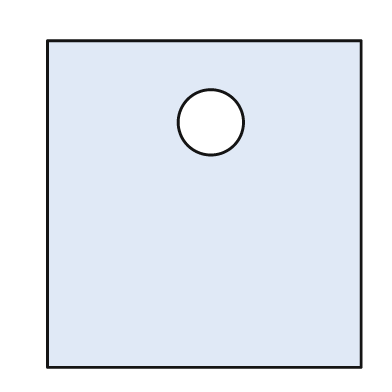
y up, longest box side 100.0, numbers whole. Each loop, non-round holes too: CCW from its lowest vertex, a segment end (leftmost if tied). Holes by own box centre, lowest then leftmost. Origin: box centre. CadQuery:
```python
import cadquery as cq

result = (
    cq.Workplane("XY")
    .moveTo(-48.0, -50.0)
    .lineTo(48.0, -50.0)
    .lineTo(48.0, 50.0)
    .lineTo(-48.0, 50.0)
    .close()
    .moveTo(2.0, 25.0)
    .circle(10.0)
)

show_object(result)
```